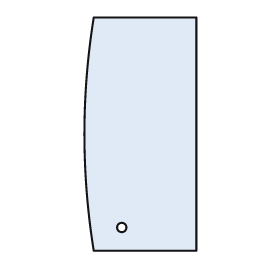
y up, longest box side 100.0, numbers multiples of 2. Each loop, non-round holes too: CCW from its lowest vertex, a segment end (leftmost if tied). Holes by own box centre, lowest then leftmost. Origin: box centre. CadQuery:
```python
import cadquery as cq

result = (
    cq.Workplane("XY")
    .moveTo(-20.0, -50.0)
    .lineTo(24.0, -50.0)
    .lineTo(24.0, 50.0)
    .lineTo(-20.0, 50.0)
    .threePointArc((-24.0, 0.0), (-20.0, -50.0))
    .close()
    .moveTo(-8.0, -40.0)
    .circle(2.0)
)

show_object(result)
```